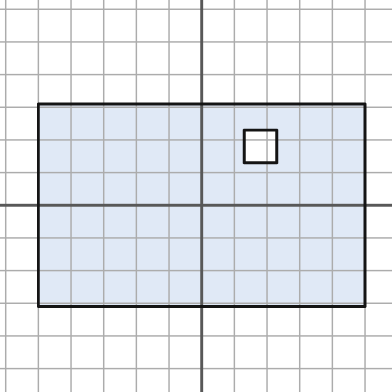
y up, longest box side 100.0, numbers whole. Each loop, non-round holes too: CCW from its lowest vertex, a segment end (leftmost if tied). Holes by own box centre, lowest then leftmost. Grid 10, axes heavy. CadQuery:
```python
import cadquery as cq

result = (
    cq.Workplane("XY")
    .moveTo(-50.0, -31.0)
    .lineTo(50.0, -31.0)
    .lineTo(50.0, 31.0)
    .lineTo(-50.0, 31.0)
    .close()
    .moveTo(13.0, 13.0)
    .lineTo(23.0, 13.0)
    .lineTo(23.0, 23.0)
    .lineTo(13.0, 23.0)
    .close()
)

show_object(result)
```